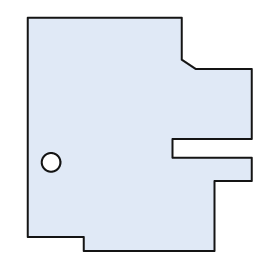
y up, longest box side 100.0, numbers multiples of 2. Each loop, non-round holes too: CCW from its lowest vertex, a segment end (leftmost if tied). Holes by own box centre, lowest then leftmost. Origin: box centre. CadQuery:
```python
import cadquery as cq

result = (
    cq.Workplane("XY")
    .moveTo(-24.0, -50.0)
    .lineTo(32.0, -50.0)
    .lineTo(32.0, -20.0)
    .lineTo(48.0, -20.0)
    .lineTo(48.0, -10.0)
    .lineTo(14.0, -10.0)
    .lineTo(14.0, -2.0)
    .lineTo(48.0, -2.0)
    .lineTo(48.0, 28.0)
    .lineTo(24.0, 28.0)
    .lineTo(18.0, 32.0)
    .lineTo(18.0, 50.0)
    .lineTo(-48.0, 50.0)
    .lineTo(-48.0, -44.0)
    .lineTo(-24.0, -44.0)
    .close()
    .moveTo(-38.0, -12.0)
    .circle(4.0)
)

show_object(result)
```